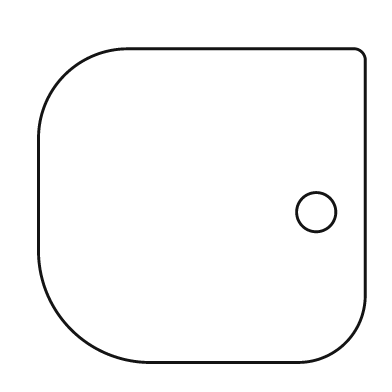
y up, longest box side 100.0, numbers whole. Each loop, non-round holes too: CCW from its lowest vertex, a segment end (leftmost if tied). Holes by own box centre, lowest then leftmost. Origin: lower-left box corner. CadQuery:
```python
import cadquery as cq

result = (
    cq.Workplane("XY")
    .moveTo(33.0, 0.0)
    .lineTo(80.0, 0.0)
    .threePointArc((94.0, 6.0), (100.0, 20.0))
    .lineTo(100.0, 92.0)
    .threePointArc((99.0, 95.0), (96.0, 96.0))
    .lineTo(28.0, 96.0)
    .threePointArc((8.0, 88.0), (0.0, 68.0))
    .lineTo(0.0, 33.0)
    .threePointArc((10.0, 10.0), (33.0, 0.0))
    .close()
    .moveTo(85.0, 46.0)
    .circle(6.0)
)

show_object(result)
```